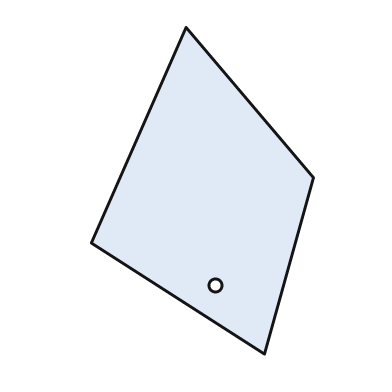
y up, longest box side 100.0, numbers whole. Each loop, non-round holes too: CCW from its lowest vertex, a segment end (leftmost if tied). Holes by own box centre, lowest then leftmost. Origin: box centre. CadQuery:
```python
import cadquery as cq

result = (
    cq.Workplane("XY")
    .moveTo(19.0, -50.0)
    .lineTo(34.0, 4.0)
    .lineTo(-5.0, 50.0)
    .lineTo(-34.0, -16.0)
    .close()
    .moveTo(4.0, -29.0)
    .circle(2.0)
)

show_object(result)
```